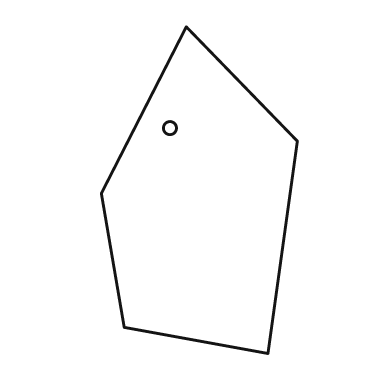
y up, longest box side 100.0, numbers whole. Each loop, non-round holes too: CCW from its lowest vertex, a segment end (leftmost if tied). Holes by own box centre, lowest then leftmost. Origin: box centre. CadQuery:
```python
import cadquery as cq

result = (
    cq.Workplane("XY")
    .moveTo(21.0, -50.0)
    .lineTo(30.0, 15.0)
    .lineTo(-4.0, 50.0)
    .lineTo(-30.0, -1.0)
    .lineTo(-23.0, -42.0)
    .close()
    .moveTo(-9.0, 19.0)
    .circle(2.0)
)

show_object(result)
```